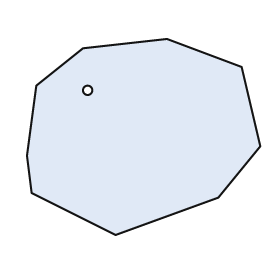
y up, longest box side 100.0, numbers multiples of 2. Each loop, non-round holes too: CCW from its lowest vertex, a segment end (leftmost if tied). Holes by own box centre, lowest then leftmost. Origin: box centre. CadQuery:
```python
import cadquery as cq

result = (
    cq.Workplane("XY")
    .moveTo(-12.0, -42.0)
    .lineTo(32.0, -26.0)
    .lineTo(50.0, -4.0)
    .lineTo(42.0, 30.0)
    .lineTo(10.0, 42.0)
    .lineTo(-26.0, 38.0)
    .lineTo(-46.0, 22.0)
    .lineTo(-50.0, -8.0)
    .lineTo(-48.0, -24.0)
    .close()
    .moveTo(-24.0, 20.0)
    .circle(2.0)
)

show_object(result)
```